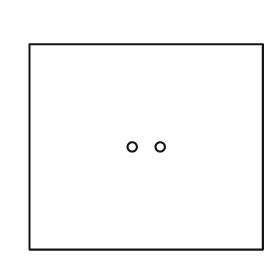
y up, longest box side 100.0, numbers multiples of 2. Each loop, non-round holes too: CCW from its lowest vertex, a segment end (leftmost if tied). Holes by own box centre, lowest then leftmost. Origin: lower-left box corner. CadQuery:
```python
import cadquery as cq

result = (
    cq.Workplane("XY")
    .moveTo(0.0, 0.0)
    .lineTo(100.0, 0.0)
    .lineTo(100.0, 88.0)
    .lineTo(0.0, 88.0)
    .close()
    .moveTo(44.0, 44.0)
    .circle(2.0)
    .moveTo(56.0, 44.0)
    .circle(2.0)
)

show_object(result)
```